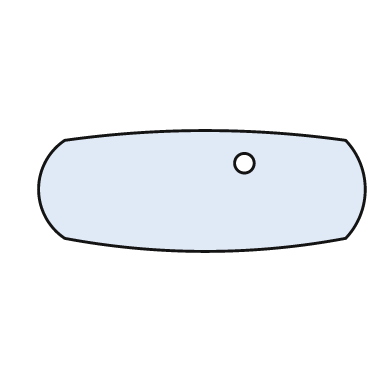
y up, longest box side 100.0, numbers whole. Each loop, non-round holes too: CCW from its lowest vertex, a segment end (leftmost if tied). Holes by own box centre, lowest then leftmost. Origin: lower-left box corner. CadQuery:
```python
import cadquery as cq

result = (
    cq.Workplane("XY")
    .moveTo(8.0, 4.0)
    .threePointArc((51.0, 0.0), (94.0, 4.0))
    .threePointArc((100.0, 19.0), (94.0, 34.0))
    .threePointArc((51.0, 37.0), (8.0, 34.0))
    .threePointArc((0.0, 19.0), (8.0, 4.0))
    .close()
    .moveTo(63.0, 27.0)
    .circle(3.0)
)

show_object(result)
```